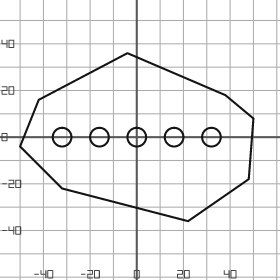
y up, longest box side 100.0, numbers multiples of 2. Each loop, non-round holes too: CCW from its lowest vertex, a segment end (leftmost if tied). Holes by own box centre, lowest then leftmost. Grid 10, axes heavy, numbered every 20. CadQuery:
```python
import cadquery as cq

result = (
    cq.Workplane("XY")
    .moveTo(22.0, -36.0)
    .lineTo(48.0, -18.0)
    .lineTo(50.0, 8.0)
    .lineTo(38.0, 18.0)
    .lineTo(-4.0, 36.0)
    .lineTo(-42.0, 16.0)
    .lineTo(-50.0, -4.0)
    .lineTo(-32.0, -22.0)
    .close()
    .moveTo(-32.0, 0.0)
    .circle(4.0)
    .moveTo(-16.0, 0.0)
    .circle(4.0)
    .moveTo(0.0, 0.0)
    .circle(4.0)
    .moveTo(16.0, 0.0)
    .circle(4.0)
    .moveTo(32.0, 0.0)
    .circle(4.0)
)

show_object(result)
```